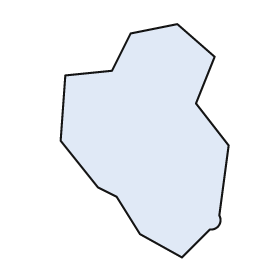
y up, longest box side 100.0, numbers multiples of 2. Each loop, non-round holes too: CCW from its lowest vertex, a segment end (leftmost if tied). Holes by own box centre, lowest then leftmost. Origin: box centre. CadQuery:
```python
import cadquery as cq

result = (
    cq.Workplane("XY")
    .moveTo(16.0, -50.0)
    .lineTo(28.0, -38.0)
    .threePointArc((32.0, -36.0), (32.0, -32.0))
    .lineTo(36.0, -2.0)
    .lineTo(22.0, 16.0)
    .lineTo(30.0, 36.0)
    .lineTo(14.0, 50.0)
    .lineTo(-6.0, 46.0)
    .lineTo(-14.0, 30.0)
    .lineTo(-34.0, 28.0)
    .lineTo(-36.0, 0.0)
    .lineTo(-20.0, -20.0)
    .lineTo(-12.0, -24.0)
    .lineTo(-2.0, -40.0)
    .close()
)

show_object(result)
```